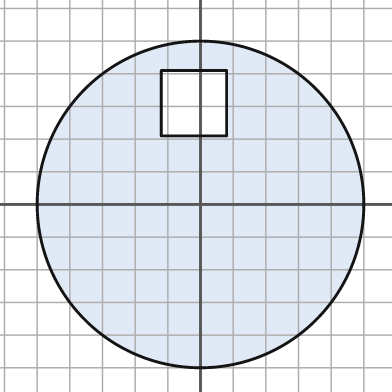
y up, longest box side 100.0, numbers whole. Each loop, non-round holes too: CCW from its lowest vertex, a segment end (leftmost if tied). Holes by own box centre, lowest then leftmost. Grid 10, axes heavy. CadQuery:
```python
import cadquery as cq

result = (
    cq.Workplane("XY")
    .moveTo(0.0, 0.0)
    .circle(50.0)
    .moveTo(-12.0, 21.0)
    .lineTo(8.0, 21.0)
    .lineTo(8.0, 41.0)
    .lineTo(-12.0, 41.0)
    .close()
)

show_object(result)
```